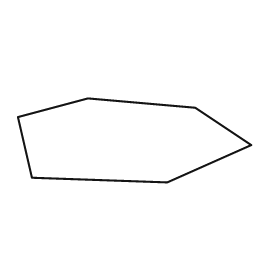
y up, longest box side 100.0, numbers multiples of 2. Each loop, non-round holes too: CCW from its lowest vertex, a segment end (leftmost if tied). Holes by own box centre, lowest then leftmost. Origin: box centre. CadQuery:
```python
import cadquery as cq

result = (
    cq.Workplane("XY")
    .moveTo(14.0, -18.0)
    .lineTo(50.0, -2.0)
    .lineTo(26.0, 14.0)
    .lineTo(-20.0, 18.0)
    .lineTo(-50.0, 10.0)
    .lineTo(-44.0, -16.0)
    .close()
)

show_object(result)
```